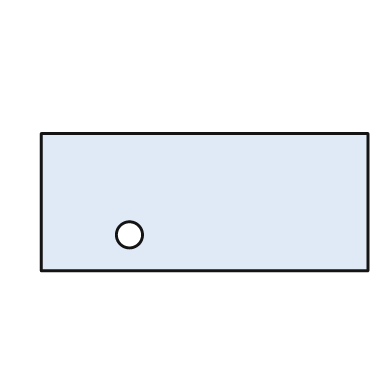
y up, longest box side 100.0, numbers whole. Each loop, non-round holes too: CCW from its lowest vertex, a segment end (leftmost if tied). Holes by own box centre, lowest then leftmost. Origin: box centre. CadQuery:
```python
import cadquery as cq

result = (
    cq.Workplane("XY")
    .moveTo(-50.0, -21.0)
    .lineTo(50.0, -21.0)
    .lineTo(50.0, 21.0)
    .lineTo(-50.0, 21.0)
    .close()
    .moveTo(-23.0, -10.0)
    .circle(4.0)
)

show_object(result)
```